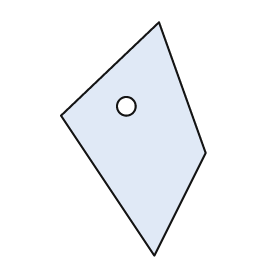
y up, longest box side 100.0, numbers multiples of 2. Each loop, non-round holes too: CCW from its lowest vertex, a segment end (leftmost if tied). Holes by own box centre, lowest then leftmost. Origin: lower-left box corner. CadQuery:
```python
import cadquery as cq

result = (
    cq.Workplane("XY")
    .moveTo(40.0, 0.0)
    .lineTo(62.0, 44.0)
    .lineTo(42.0, 100.0)
    .lineTo(0.0, 60.0)
    .close()
    .moveTo(28.0, 64.0)
    .circle(4.0)
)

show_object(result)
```